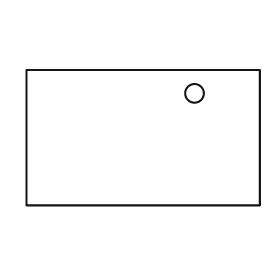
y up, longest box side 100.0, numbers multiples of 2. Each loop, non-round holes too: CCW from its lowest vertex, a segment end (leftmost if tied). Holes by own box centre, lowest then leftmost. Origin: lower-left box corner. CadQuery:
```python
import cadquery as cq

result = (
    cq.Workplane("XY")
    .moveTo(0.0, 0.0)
    .lineTo(100.0, 0.0)
    .lineTo(100.0, 58.0)
    .lineTo(0.0, 58.0)
    .close()
    .moveTo(72.0, 48.0)
    .circle(4.0)
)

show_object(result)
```